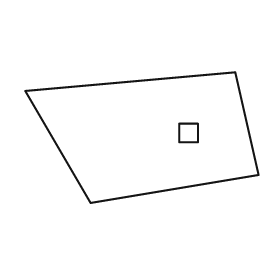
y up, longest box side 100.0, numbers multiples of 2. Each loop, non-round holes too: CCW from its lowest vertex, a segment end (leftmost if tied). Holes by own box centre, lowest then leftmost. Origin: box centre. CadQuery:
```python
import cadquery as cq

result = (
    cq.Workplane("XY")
    .moveTo(-22.0, -28.0)
    .lineTo(50.0, -16.0)
    .lineTo(40.0, 28.0)
    .lineTo(-50.0, 20.0)
    .close()
    .moveTo(16.0, -2.0)
    .lineTo(24.0, -2.0)
    .lineTo(24.0, 6.0)
    .lineTo(16.0, 6.0)
    .close()
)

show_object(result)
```